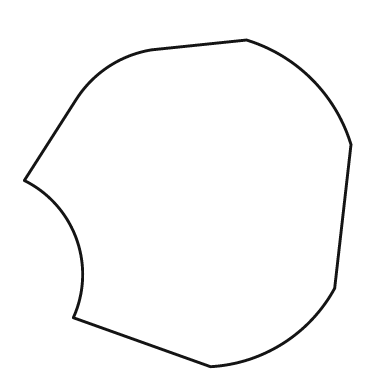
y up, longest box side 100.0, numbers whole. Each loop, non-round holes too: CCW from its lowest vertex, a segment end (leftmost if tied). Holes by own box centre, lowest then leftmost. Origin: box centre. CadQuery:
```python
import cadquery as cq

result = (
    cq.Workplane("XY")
    .moveTo(7.0, -50.0)
    .threePointArc((29.0, -43.0), (45.0, -26.0))
    .lineTo(50.0, 18.0)
    .threePointArc((38.0, 38.0), (18.0, 50.0))
    .lineTo(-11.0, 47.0)
    .threePointArc((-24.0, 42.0), (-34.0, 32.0))
    .lineTo(-50.0, 7.0)
    .threePointArc((-34.0, -11.0), (-35.0, -35.0))
    .close()
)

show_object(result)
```